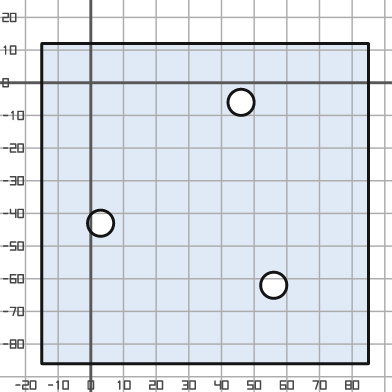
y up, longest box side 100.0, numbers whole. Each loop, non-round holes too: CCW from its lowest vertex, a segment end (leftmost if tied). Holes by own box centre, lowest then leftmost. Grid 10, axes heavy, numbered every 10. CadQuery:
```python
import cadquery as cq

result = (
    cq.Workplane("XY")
    .moveTo(-15.0, -86.0)
    .lineTo(85.0, -86.0)
    .lineTo(85.0, 12.0)
    .lineTo(-15.0, 12.0)
    .close()
    .moveTo(56.0, -62.0)
    .circle(4.0)
    .moveTo(3.0, -43.0)
    .circle(4.0)
    .moveTo(46.0, -6.0)
    .circle(4.0)
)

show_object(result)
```